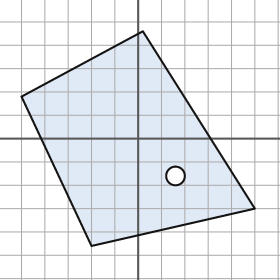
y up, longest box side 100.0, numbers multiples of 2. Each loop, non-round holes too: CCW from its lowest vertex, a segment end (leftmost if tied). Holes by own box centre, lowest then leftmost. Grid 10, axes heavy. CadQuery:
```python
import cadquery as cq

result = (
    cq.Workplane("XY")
    .moveTo(-20.0, -46.0)
    .lineTo(50.0, -30.0)
    .lineTo(2.0, 46.0)
    .lineTo(-50.0, 18.0)
    .close()
    .moveTo(16.0, -16.0)
    .circle(4.0)
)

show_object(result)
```